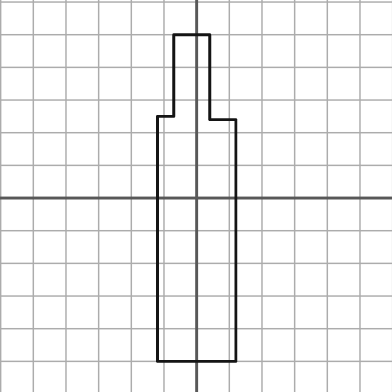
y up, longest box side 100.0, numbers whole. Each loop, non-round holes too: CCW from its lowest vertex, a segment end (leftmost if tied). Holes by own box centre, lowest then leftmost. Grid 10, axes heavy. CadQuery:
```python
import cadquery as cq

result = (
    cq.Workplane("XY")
    .moveTo(-12.0, -50.0)
    .lineTo(12.0, -50.0)
    .lineTo(12.0, 24.0)
    .lineTo(4.0, 24.0)
    .lineTo(4.0, 50.0)
    .lineTo(-7.0, 50.0)
    .lineTo(-7.0, 25.0)
    .lineTo(-12.0, 25.0)
    .close()
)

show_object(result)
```